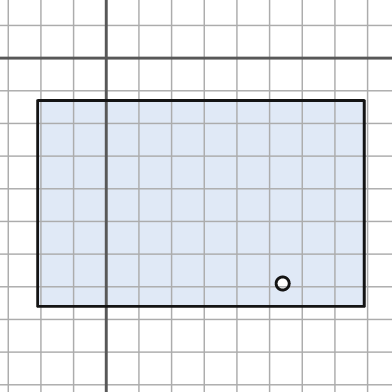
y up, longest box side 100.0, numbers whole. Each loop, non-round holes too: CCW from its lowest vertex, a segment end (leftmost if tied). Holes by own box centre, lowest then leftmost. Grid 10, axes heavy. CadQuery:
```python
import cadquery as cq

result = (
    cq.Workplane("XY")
    .moveTo(-21.0, -76.0)
    .lineTo(79.0, -76.0)
    .lineTo(79.0, -13.0)
    .lineTo(-21.0, -13.0)
    .close()
    .moveTo(54.0, -69.0)
    .circle(2.0)
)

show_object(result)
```